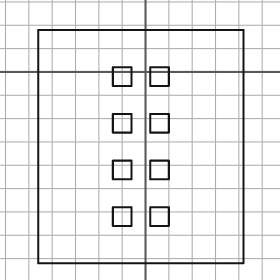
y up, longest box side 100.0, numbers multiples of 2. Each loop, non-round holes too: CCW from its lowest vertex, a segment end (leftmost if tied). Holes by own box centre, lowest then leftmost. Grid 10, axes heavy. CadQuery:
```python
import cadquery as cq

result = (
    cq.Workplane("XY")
    .moveTo(-46.0, -82.0)
    .lineTo(42.0, -82.0)
    .lineTo(42.0, 18.0)
    .lineTo(-46.0, 18.0)
    .close()
    .moveTo(-14.0, -66.0)
    .lineTo(-6.0, -66.0)
    .lineTo(-6.0, -58.0)
    .lineTo(-14.0, -58.0)
    .close()
    .moveTo(2.0, -66.0)
    .lineTo(10.0, -66.0)
    .lineTo(10.0, -58.0)
    .lineTo(2.0, -58.0)
    .close()
    .moveTo(-14.0, -46.0)
    .lineTo(-6.0, -46.0)
    .lineTo(-6.0, -38.0)
    .lineTo(-14.0, -38.0)
    .close()
    .moveTo(2.0, -46.0)
    .lineTo(10.0, -46.0)
    .lineTo(10.0, -38.0)
    .lineTo(2.0, -38.0)
    .close()
    .moveTo(-14.0, -26.0)
    .lineTo(-6.0, -26.0)
    .lineTo(-6.0, -18.0)
    .lineTo(-14.0, -18.0)
    .close()
    .moveTo(2.0, -26.0)
    .lineTo(10.0, -26.0)
    .lineTo(10.0, -18.0)
    .lineTo(2.0, -18.0)
    .close()
    .moveTo(-14.0, -6.0)
    .lineTo(-6.0, -6.0)
    .lineTo(-6.0, 2.0)
    .lineTo(-14.0, 2.0)
    .close()
    .moveTo(2.0, -6.0)
    .lineTo(10.0, -6.0)
    .lineTo(10.0, 2.0)
    .lineTo(2.0, 2.0)
    .close()
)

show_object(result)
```